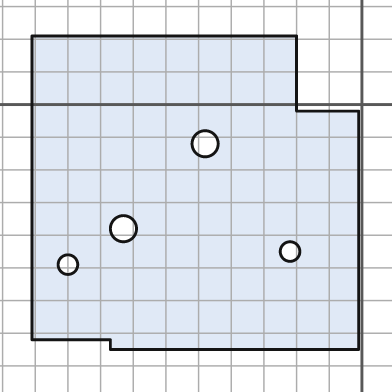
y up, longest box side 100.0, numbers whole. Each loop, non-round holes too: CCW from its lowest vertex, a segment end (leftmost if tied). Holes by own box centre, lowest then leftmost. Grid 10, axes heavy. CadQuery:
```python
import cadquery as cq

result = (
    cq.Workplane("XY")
    .moveTo(-77.0, -75.0)
    .lineTo(-1.0, -75.0)
    .lineTo(-1.0, -2.0)
    .lineTo(-20.0, -2.0)
    .lineTo(-20.0, 21.0)
    .lineTo(-101.0, 21.0)
    .lineTo(-101.0, -72.0)
    .lineTo(-77.0, -72.0)
    .close()
    .moveTo(-90.0, -49.0)
    .circle(3.0)
    .moveTo(-22.0, -45.0)
    .circle(3.0)
    .moveTo(-73.0, -38.0)
    .circle(4.0)
    .moveTo(-48.0, -12.0)
    .circle(4.0)
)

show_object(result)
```